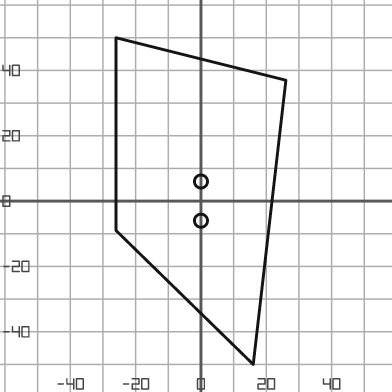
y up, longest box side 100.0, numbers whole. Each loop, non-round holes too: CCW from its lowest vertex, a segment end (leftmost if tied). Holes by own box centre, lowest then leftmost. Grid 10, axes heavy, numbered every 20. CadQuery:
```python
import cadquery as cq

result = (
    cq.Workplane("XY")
    .moveTo(16.0, -50.0)
    .lineTo(26.0, 37.0)
    .lineTo(-26.0, 50.0)
    .lineTo(-26.0, -9.0)
    .close()
    .moveTo(0.0, -6.0)
    .circle(2.0)
    .moveTo(0.0, 6.0)
    .circle(2.0)
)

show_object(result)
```